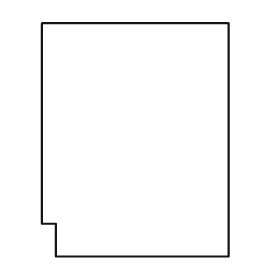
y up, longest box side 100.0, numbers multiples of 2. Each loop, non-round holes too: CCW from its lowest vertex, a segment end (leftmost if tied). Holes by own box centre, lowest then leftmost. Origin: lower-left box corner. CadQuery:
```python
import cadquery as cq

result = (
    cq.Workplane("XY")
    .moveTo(6.0, 0.0)
    .lineTo(80.0, 0.0)
    .lineTo(80.0, 100.0)
    .lineTo(0.0, 100.0)
    .lineTo(0.0, 14.0)
    .lineTo(6.0, 14.0)
    .close()
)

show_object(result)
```